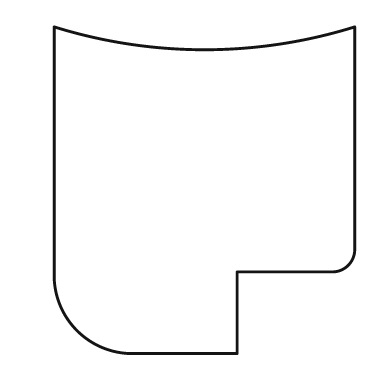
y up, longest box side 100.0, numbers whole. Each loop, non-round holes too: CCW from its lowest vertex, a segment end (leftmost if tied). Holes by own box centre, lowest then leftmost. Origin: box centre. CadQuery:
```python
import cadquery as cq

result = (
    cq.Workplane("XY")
    .moveTo(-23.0, -50.0)
    .lineTo(10.0, -50.0)
    .lineTo(10.0, -25.0)
    .lineTo(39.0, -25.0)
    .threePointArc((44.0, -23.0), (46.0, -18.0))
    .lineTo(46.0, 50.0)
    .threePointArc((0.0, 43.0), (-46.0, 50.0))
    .lineTo(-46.0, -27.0)
    .threePointArc((-39.0, -43.0), (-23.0, -50.0))
    .close()
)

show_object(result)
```